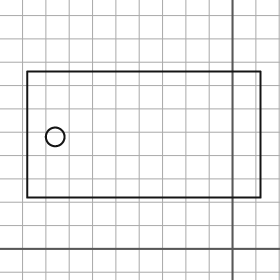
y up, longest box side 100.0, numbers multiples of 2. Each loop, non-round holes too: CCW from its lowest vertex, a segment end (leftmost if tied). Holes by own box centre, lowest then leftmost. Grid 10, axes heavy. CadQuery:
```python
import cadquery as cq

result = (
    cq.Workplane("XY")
    .moveTo(-88.0, 22.0)
    .lineTo(12.0, 22.0)
    .lineTo(12.0, 76.0)
    .lineTo(-88.0, 76.0)
    .close()
    .moveTo(-76.0, 48.0)
    .circle(4.0)
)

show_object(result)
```